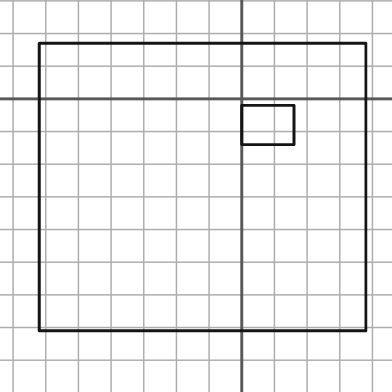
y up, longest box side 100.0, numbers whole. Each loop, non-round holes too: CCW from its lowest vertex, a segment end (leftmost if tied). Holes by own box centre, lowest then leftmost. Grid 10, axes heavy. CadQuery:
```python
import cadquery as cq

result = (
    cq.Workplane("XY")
    .moveTo(-62.0, -71.0)
    .lineTo(38.0, -71.0)
    .lineTo(38.0, 17.0)
    .lineTo(-62.0, 17.0)
    .close()
    .moveTo(0.0, -14.0)
    .lineTo(16.0, -14.0)
    .lineTo(16.0, -2.0)
    .lineTo(0.0, -2.0)
    .close()
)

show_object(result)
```